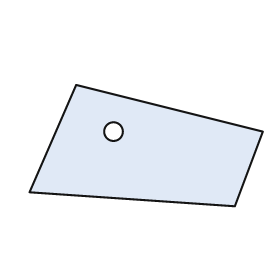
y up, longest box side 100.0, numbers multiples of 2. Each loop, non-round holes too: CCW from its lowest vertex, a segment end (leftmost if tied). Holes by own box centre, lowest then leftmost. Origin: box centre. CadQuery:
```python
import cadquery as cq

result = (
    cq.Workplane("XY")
    .moveTo(38.0, -26.0)
    .lineTo(50.0, 6.0)
    .lineTo(-30.0, 26.0)
    .lineTo(-50.0, -20.0)
    .close()
    .moveTo(-14.0, 6.0)
    .circle(4.0)
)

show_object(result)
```